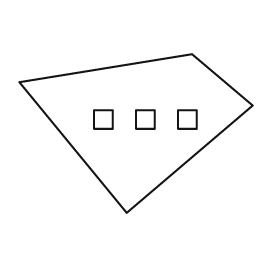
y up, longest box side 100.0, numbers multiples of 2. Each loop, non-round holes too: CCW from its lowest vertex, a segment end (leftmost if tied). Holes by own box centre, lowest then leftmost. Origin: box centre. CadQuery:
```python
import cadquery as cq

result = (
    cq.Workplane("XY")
    .moveTo(-4.0, -34.0)
    .lineTo(50.0, 12.0)
    .lineTo(24.0, 34.0)
    .lineTo(-50.0, 22.0)
    .close()
    .moveTo(-18.0, 2.0)
    .lineTo(-10.0, 2.0)
    .lineTo(-10.0, 10.0)
    .lineTo(-18.0, 10.0)
    .close()
    .moveTo(0.0, 2.0)
    .lineTo(8.0, 2.0)
    .lineTo(8.0, 10.0)
    .lineTo(0.0, 10.0)
    .close()
    .moveTo(18.0, 2.0)
    .lineTo(26.0, 2.0)
    .lineTo(26.0, 10.0)
    .lineTo(18.0, 10.0)
    .close()
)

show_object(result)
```